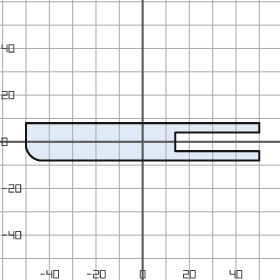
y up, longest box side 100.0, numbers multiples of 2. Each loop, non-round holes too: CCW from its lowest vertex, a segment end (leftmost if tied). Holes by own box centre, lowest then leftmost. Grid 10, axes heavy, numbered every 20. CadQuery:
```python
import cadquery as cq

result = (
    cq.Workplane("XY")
    .moveTo(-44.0, -8.0)
    .lineTo(50.0, -8.0)
    .lineTo(50.0, -4.0)
    .lineTo(14.0, -4.0)
    .lineTo(14.0, 4.0)
    .lineTo(50.0, 4.0)
    .lineTo(50.0, 8.0)
    .lineTo(-50.0, 8.0)
    .lineTo(-50.0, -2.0)
    .threePointArc((-48.0, -6.0), (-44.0, -8.0))
    .close()
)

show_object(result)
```